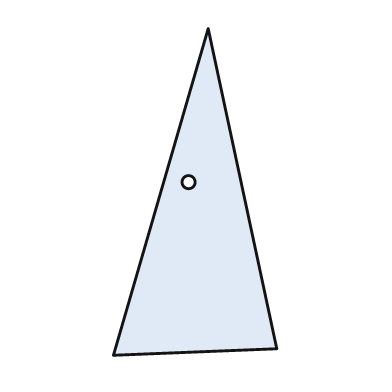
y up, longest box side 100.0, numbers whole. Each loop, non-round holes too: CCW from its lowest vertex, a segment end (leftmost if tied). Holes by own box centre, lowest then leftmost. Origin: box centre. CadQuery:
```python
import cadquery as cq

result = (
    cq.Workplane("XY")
    .moveTo(-25.0, -50.0)
    .lineTo(25.0, -48.0)
    .lineTo(4.0, 50.0)
    .close()
    .moveTo(-2.0, 3.0)
    .circle(2.0)
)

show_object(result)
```